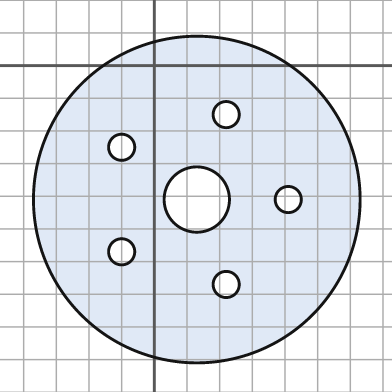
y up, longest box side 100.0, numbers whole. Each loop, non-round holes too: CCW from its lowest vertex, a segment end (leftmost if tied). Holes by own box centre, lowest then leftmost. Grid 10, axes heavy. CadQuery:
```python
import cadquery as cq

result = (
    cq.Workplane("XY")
    .moveTo(13.0, -41.0)
    .circle(50.0)
    .moveTo(22.0, -67.0)
    .circle(4.0)
    .moveTo(-10.0, -57.0)
    .circle(4.0)
    .moveTo(13.0, -41.0)
    .circle(10.0)
    .moveTo(41.0, -41.0)
    .circle(4.0)
    .moveTo(-10.0, -25.0)
    .circle(4.0)
    .moveTo(22.0, -15.0)
    .circle(4.0)
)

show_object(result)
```